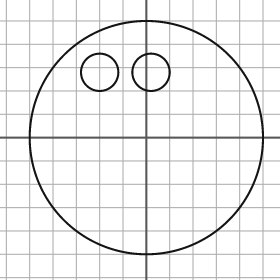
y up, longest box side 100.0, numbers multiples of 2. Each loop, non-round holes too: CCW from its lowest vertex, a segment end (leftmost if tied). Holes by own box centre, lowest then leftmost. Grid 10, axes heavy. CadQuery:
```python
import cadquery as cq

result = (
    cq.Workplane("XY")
    .moveTo(0.0, 0.0)
    .circle(50.0)
    .moveTo(-20.0, 28.0)
    .circle(8.0)
    .moveTo(2.0, 28.0)
    .circle(8.0)
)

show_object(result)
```